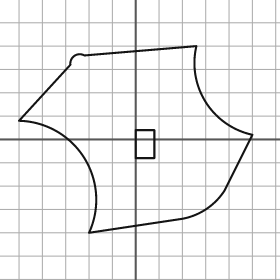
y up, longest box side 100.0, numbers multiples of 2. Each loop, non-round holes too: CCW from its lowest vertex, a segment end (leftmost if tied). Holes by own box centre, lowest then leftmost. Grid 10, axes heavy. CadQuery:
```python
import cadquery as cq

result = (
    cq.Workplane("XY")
    .moveTo(-20.0, -40.0)
    .lineTo(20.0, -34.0)
    .threePointArc((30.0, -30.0), (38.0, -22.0))
    .lineTo(50.0, 2.0)
    .threePointArc((30.0, 16.0), (26.0, 40.0))
    .lineTo(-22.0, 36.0)
    .threePointArc((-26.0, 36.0), (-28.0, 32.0))
    .lineTo(-50.0, 8.0)
    .threePointArc((-22.0, -8.0), (-20.0, -40.0))
    .close()
    .moveTo(0.0, -8.0)
    .lineTo(8.0, -8.0)
    .lineTo(8.0, 4.0)
    .lineTo(0.0, 4.0)
    .close()
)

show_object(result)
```